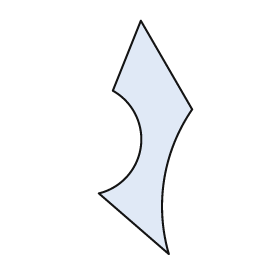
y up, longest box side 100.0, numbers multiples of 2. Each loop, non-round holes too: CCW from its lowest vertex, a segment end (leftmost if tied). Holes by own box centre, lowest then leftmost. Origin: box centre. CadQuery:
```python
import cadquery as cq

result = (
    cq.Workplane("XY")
    .moveTo(10.0, -50.0)
    .threePointArc((8.0, -18.0), (20.0, 12.0))
    .lineTo(-2.0, 50.0)
    .lineTo(-14.0, 20.0)
    .threePointArc((-2.0, -4.0), (-20.0, -24.0))
    .close()
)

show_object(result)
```